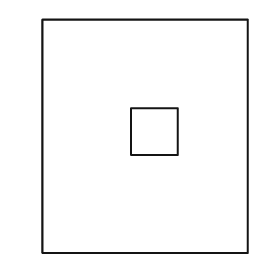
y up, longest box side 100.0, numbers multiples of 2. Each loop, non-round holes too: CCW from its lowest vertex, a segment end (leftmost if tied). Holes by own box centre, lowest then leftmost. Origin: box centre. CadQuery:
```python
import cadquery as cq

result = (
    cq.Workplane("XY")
    .moveTo(-44.0, -50.0)
    .lineTo(44.0, -50.0)
    .lineTo(44.0, 50.0)
    .lineTo(-44.0, 50.0)
    .close()
    .moveTo(-6.0, -8.0)
    .lineTo(14.0, -8.0)
    .lineTo(14.0, 12.0)
    .lineTo(-6.0, 12.0)
    .close()
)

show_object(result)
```